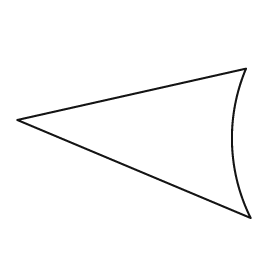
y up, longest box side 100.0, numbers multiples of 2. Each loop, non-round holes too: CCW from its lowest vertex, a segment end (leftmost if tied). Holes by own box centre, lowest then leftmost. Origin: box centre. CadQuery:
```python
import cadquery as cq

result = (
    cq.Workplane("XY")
    .moveTo(50.0, -32.0)
    .threePointArc((42.0, 0.0), (48.0, 32.0))
    .lineTo(-50.0, 10.0)
    .close()
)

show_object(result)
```